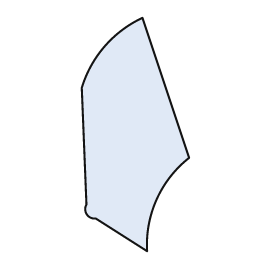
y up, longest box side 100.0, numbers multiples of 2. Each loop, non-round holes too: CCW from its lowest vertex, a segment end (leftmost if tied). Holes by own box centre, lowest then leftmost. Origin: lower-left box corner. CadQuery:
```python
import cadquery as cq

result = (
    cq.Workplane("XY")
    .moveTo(28.0, 0.0)
    .threePointArc((32.0, 22.0), (46.0, 40.0))
    .lineTo(26.0, 100.0)
    .threePointArc((10.0, 88.0), (0.0, 70.0))
    .lineTo(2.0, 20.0)
    .threePointArc((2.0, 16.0), (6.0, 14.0))
    .close()
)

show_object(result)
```